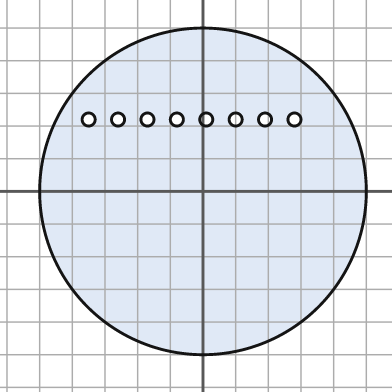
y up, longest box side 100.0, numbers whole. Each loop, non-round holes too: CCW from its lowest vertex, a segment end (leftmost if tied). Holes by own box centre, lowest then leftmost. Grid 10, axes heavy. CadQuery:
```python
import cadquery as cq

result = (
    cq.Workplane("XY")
    .moveTo(0.0, 0.0)
    .circle(50.0)
    .moveTo(-35.0, 22.0)
    .circle(2.0)
    .moveTo(-26.0, 22.0)
    .circle(2.0)
    .moveTo(-17.0, 22.0)
    .circle(2.0)
    .moveTo(-8.0, 22.0)
    .circle(2.0)
    .moveTo(1.0, 22.0)
    .circle(2.0)
    .moveTo(10.0, 22.0)
    .circle(2.0)
    .moveTo(19.0, 22.0)
    .circle(2.0)
    .moveTo(28.0, 22.0)
    .circle(2.0)
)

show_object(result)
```